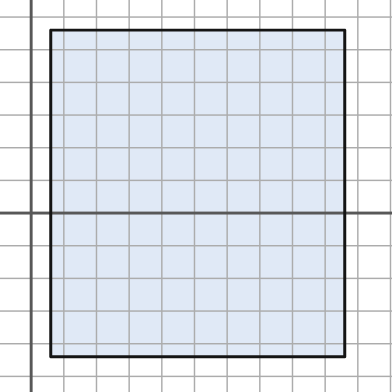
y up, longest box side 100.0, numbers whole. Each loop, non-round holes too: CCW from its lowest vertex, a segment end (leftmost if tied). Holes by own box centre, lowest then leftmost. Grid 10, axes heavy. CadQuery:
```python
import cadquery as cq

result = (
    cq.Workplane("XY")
    .moveTo(6.0, -44.0)
    .lineTo(96.0, -44.0)
    .lineTo(96.0, 56.0)
    .lineTo(6.0, 56.0)
    .close()
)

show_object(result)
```